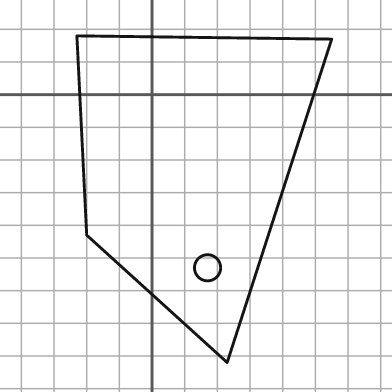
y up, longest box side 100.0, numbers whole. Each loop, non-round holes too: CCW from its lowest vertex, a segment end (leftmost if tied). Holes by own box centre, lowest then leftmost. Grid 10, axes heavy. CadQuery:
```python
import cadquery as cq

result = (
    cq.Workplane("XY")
    .moveTo(23.0, -82.0)
    .lineTo(55.0, 17.0)
    .lineTo(-23.0, 18.0)
    .lineTo(-20.0, -43.0)
    .close()
    .moveTo(17.0, -53.0)
    .circle(4.0)
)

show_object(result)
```